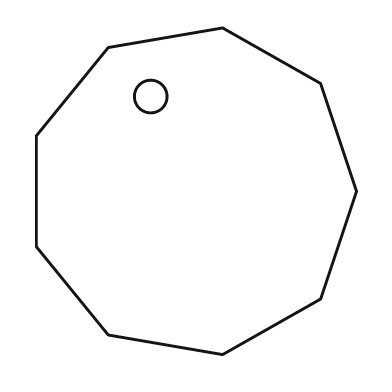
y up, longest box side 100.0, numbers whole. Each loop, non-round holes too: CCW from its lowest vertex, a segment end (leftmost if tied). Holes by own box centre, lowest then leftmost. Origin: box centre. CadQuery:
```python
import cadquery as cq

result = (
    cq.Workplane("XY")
    .moveTo(8.0, -50.0)
    .lineTo(38.0, -33.0)
    .lineTo(49.0, 0.0)
    .lineTo(38.0, 33.0)
    .lineTo(8.0, 50.0)
    .lineTo(-27.0, 44.0)
    .lineTo(-49.0, 17.0)
    .lineTo(-49.0, -17.0)
    .lineTo(-27.0, -44.0)
    .close()
    .moveTo(-14.0, 29.0)
    .circle(5.0)
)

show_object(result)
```